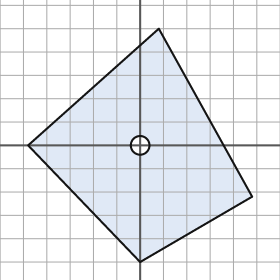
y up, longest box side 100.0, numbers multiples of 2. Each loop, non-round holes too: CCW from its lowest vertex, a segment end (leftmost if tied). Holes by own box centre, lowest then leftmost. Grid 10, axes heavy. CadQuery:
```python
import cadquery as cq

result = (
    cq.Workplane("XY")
    .moveTo(0.0, -50.0)
    .lineTo(48.0, -22.0)
    .lineTo(8.0, 50.0)
    .lineTo(-48.0, 0.0)
    .close()
    .moveTo(0.0, 0.0)
    .circle(4.0)
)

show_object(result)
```